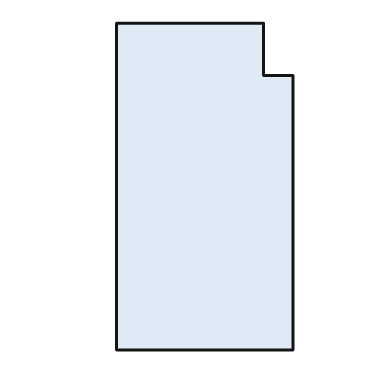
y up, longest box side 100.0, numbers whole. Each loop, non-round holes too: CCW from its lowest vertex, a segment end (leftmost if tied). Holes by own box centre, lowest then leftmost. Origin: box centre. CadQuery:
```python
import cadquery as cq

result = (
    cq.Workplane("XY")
    .moveTo(-27.0, -50.0)
    .lineTo(27.0, -50.0)
    .lineTo(27.0, 34.0)
    .lineTo(18.0, 34.0)
    .lineTo(18.0, 50.0)
    .lineTo(-27.0, 50.0)
    .close()
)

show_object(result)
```